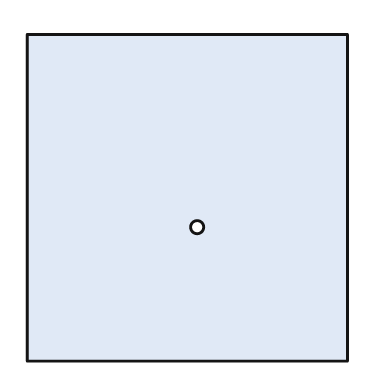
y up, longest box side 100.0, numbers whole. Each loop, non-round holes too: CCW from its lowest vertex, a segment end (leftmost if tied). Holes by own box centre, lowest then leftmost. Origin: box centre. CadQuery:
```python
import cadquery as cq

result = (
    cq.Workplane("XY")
    .moveTo(-49.0, -50.0)
    .lineTo(49.0, -50.0)
    .lineTo(49.0, 50.0)
    .lineTo(-49.0, 50.0)
    .close()
    .moveTo(3.0, -9.0)
    .circle(2.0)
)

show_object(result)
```